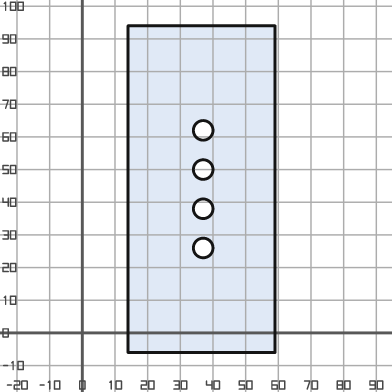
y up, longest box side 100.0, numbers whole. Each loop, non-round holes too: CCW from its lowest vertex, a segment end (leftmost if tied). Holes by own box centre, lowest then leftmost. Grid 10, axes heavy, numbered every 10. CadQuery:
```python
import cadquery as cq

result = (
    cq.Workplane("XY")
    .moveTo(14.0, -6.0)
    .lineTo(59.0, -6.0)
    .lineTo(59.0, 94.0)
    .lineTo(14.0, 94.0)
    .close()
    .moveTo(37.0, 26.0)
    .circle(3.0)
    .moveTo(37.0, 38.0)
    .circle(3.0)
    .moveTo(37.0, 50.0)
    .circle(3.0)
    .moveTo(37.0, 62.0)
    .circle(3.0)
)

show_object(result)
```